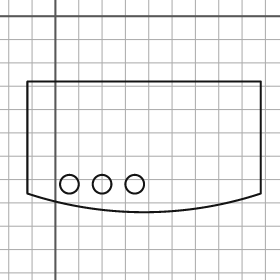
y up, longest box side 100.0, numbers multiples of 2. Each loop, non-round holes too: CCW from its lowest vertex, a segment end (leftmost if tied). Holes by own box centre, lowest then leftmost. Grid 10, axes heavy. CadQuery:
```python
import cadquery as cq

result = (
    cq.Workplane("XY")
    .moveTo(-12.0, -76.0)
    .threePointArc((38.0, -84.0), (88.0, -76.0))
    .lineTo(88.0, -28.0)
    .lineTo(-12.0, -28.0)
    .close()
    .moveTo(6.0, -72.0)
    .circle(4.0)
    .moveTo(20.0, -72.0)
    .circle(4.0)
    .moveTo(34.0, -72.0)
    .circle(4.0)
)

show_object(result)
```